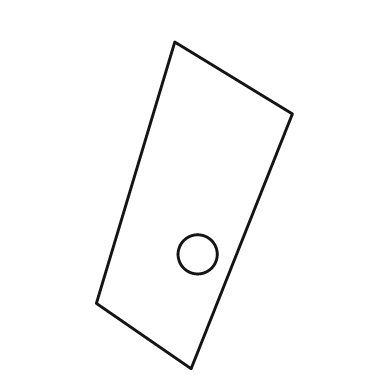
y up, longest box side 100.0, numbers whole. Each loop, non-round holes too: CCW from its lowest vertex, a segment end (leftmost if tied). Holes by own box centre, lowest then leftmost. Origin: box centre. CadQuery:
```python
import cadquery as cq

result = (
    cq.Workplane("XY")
    .moveTo(-1.0, -50.0)
    .lineTo(30.0, 28.0)
    .lineTo(-6.0, 50.0)
    .lineTo(-30.0, -30.0)
    .close()
    .moveTo(1.0, -15.0)
    .circle(6.0)
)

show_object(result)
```